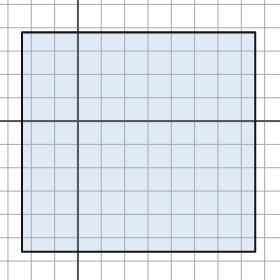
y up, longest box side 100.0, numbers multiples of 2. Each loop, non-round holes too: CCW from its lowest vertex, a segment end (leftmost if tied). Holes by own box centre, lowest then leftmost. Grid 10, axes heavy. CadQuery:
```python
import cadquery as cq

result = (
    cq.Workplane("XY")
    .moveTo(-24.0, -56.0)
    .lineTo(76.0, -56.0)
    .lineTo(76.0, 38.0)
    .lineTo(-24.0, 38.0)
    .close()
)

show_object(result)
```